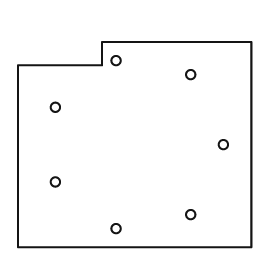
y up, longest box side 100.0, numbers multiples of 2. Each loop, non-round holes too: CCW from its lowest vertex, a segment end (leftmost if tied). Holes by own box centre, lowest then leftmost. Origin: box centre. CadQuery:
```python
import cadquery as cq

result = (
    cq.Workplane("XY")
    .moveTo(-50.0, -44.0)
    .lineTo(50.0, -44.0)
    .lineTo(50.0, 44.0)
    .lineTo(-14.0, 44.0)
    .lineTo(-14.0, 34.0)
    .lineTo(-50.0, 34.0)
    .close()
    .moveTo(-8.0, -36.0)
    .circle(2.0)
    .moveTo(24.0, -30.0)
    .circle(2.0)
    .moveTo(-34.0, -16.0)
    .circle(2.0)
    .moveTo(38.0, 0.0)
    .circle(2.0)
    .moveTo(-34.0, 16.0)
    .circle(2.0)
    .moveTo(24.0, 30.0)
    .circle(2.0)
    .moveTo(-8.0, 36.0)
    .circle(2.0)
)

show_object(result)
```